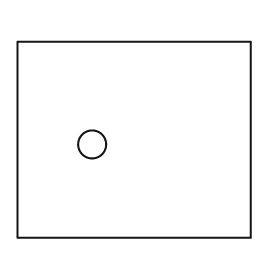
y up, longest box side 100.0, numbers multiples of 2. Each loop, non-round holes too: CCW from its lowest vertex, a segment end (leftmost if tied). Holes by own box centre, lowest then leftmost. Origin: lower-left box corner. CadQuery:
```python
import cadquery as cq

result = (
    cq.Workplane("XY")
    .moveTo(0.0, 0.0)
    .lineTo(100.0, 0.0)
    .lineTo(100.0, 84.0)
    .lineTo(0.0, 84.0)
    .close()
    .moveTo(32.0, 40.0)
    .circle(6.0)
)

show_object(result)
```